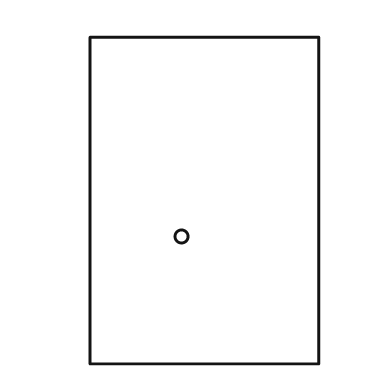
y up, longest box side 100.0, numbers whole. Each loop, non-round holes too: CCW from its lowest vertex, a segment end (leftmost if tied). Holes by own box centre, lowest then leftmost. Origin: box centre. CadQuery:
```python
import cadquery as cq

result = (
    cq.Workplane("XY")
    .moveTo(-35.0, -50.0)
    .lineTo(35.0, -50.0)
    .lineTo(35.0, 50.0)
    .lineTo(-35.0, 50.0)
    .close()
    .moveTo(-7.0, -11.0)
    .circle(2.0)
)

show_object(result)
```